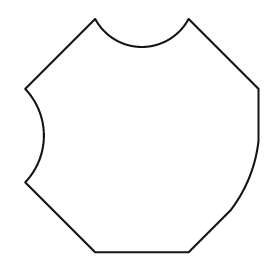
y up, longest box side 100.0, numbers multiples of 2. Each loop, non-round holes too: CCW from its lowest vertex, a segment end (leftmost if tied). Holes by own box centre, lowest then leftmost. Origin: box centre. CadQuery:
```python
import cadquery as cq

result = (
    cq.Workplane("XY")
    .moveTo(-20.0, -50.0)
    .lineTo(20.0, -50.0)
    .lineTo(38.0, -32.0)
    .threePointArc((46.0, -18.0), (50.0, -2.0))
    .lineTo(50.0, 20.0)
    .lineTo(20.0, 50.0)
    .threePointArc((0.0, 38.0), (-20.0, 50.0))
    .lineTo(-50.0, 20.0)
    .threePointArc((-42.0, 0.0), (-50.0, -20.0))
    .close()
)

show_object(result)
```